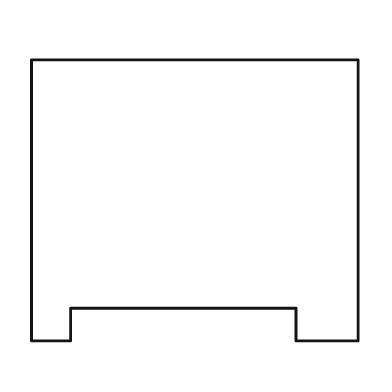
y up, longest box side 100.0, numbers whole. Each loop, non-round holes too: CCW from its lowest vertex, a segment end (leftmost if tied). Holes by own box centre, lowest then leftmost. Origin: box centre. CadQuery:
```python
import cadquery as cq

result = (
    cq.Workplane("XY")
    .moveTo(-50.0, -43.0)
    .lineTo(-38.0, -43.0)
    .lineTo(-38.0, -33.0)
    .lineTo(31.0, -33.0)
    .lineTo(31.0, -43.0)
    .lineTo(50.0, -43.0)
    .lineTo(50.0, 43.0)
    .lineTo(-50.0, 43.0)
    .close()
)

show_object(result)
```